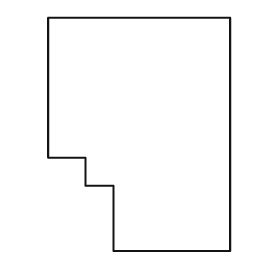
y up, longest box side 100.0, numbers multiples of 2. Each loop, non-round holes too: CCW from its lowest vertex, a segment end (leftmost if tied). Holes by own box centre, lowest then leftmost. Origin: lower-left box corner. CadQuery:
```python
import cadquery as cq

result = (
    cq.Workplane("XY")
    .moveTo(28.0, 0.0)
    .lineTo(78.0, 0.0)
    .lineTo(78.0, 100.0)
    .lineTo(0.0, 100.0)
    .lineTo(0.0, 40.0)
    .lineTo(16.0, 40.0)
    .lineTo(16.0, 28.0)
    .lineTo(28.0, 28.0)
    .close()
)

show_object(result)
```